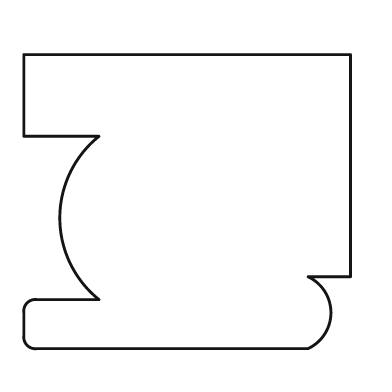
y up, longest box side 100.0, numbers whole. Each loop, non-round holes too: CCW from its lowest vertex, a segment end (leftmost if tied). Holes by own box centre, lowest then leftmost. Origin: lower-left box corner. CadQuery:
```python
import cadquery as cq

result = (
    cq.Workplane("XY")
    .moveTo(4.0, 0.0)
    .lineTo(87.0, 0.0)
    .threePointArc((94.0, 11.0), (87.0, 22.0))
    .lineTo(100.0, 22.0)
    .lineTo(100.0, 90.0)
    .lineTo(0.0, 90.0)
    .lineTo(0.0, 65.0)
    .lineTo(23.0, 65.0)
    .threePointArc((11.0, 40.0), (23.0, 15.0))
    .lineTo(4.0, 15.0)
    .threePointArc((1.0, 14.0), (0.0, 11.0))
    .lineTo(0.0, 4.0)
    .threePointArc((1.0, 1.0), (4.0, 0.0))
    .close()
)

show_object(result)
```